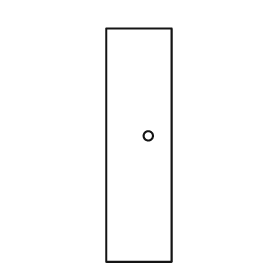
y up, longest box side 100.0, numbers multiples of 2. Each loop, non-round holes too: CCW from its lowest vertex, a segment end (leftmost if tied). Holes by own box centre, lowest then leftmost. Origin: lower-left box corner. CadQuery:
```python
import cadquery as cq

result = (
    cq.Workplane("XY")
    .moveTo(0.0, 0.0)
    .lineTo(28.0, 0.0)
    .lineTo(28.0, 100.0)
    .lineTo(0.0, 100.0)
    .close()
    .moveTo(18.0, 54.0)
    .circle(2.0)
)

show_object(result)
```